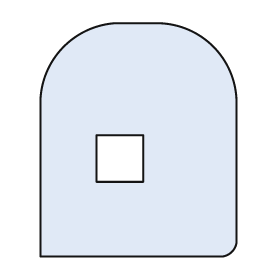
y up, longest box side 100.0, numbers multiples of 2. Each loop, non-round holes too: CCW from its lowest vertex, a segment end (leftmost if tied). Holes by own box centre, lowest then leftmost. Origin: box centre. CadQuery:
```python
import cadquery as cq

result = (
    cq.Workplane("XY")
    .moveTo(-42.0, -50.0)
    .lineTo(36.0, -50.0)
    .threePointArc((40.0, -48.0), (42.0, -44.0))
    .lineTo(42.0, 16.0)
    .threePointArc((32.0, 40.0), (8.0, 50.0))
    .lineTo(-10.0, 50.0)
    .threePointArc((-32.0, 40.0), (-42.0, 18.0))
    .close()
    .moveTo(-18.0, -18.0)
    .lineTo(2.0, -18.0)
    .lineTo(2.0, 2.0)
    .lineTo(-18.0, 2.0)
    .close()
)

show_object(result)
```